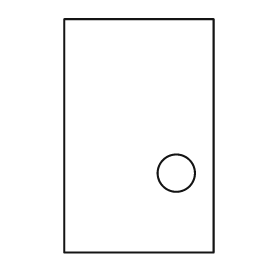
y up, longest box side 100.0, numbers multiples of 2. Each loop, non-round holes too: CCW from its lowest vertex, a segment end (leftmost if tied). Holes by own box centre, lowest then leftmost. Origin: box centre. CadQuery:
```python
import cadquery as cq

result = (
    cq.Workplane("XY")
    .moveTo(-32.0, -50.0)
    .lineTo(32.0, -50.0)
    .lineTo(32.0, 50.0)
    .lineTo(-32.0, 50.0)
    .close()
    .moveTo(16.0, -16.0)
    .circle(8.0)
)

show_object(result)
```